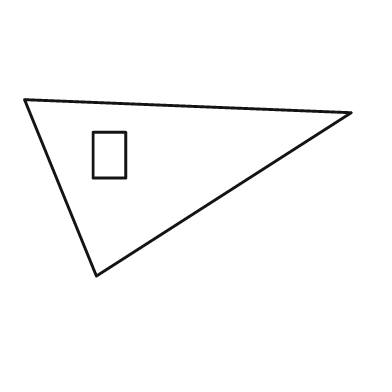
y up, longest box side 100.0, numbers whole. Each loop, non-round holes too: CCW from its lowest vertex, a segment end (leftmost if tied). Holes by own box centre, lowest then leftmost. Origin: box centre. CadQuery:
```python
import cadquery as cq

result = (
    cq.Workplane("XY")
    .moveTo(-28.0, -27.0)
    .lineTo(50.0, 23.0)
    .lineTo(-50.0, 27.0)
    .close()
    .moveTo(-29.0, 3.0)
    .lineTo(-19.0, 3.0)
    .lineTo(-19.0, 17.0)
    .lineTo(-29.0, 17.0)
    .close()
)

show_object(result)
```